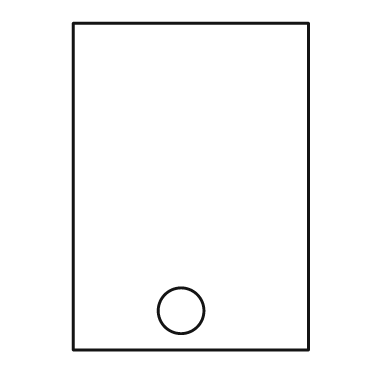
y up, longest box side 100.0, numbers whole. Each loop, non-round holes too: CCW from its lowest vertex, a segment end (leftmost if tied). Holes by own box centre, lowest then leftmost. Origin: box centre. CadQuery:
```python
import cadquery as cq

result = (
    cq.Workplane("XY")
    .moveTo(-36.0, -50.0)
    .lineTo(36.0, -50.0)
    .lineTo(36.0, 50.0)
    .lineTo(-36.0, 50.0)
    .close()
    .moveTo(-3.0, -38.0)
    .circle(7.0)
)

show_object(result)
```